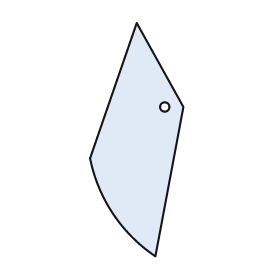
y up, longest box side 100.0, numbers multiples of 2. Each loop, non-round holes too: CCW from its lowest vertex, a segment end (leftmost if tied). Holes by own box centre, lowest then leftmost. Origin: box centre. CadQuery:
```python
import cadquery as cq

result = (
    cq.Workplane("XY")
    .moveTo(8.0, -50.0)
    .lineTo(20.0, 14.0)
    .lineTo(0.0, 50.0)
    .lineTo(-20.0, -8.0)
    .threePointArc((-10.0, -32.0), (8.0, -50.0))
    .close()
    .moveTo(12.0, 14.0)
    .circle(2.0)
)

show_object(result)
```